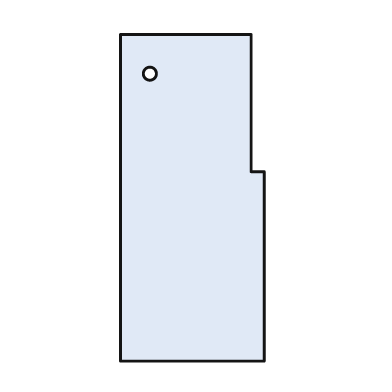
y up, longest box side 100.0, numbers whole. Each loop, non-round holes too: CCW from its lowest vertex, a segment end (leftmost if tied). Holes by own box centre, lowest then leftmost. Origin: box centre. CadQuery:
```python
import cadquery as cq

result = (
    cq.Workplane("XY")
    .moveTo(-22.0, -50.0)
    .lineTo(22.0, -50.0)
    .lineTo(22.0, 8.0)
    .lineTo(18.0, 8.0)
    .lineTo(18.0, 50.0)
    .lineTo(-22.0, 50.0)
    .close()
    .moveTo(-13.0, 38.0)
    .circle(2.0)
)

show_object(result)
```